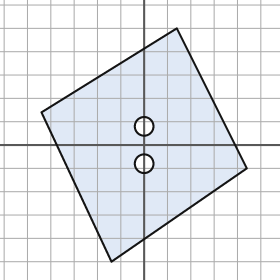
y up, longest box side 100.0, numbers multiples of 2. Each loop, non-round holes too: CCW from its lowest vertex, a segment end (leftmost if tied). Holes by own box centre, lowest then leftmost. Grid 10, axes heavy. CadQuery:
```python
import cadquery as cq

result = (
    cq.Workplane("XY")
    .moveTo(-14.0, -50.0)
    .lineTo(44.0, -10.0)
    .lineTo(14.0, 50.0)
    .lineTo(-44.0, 14.0)
    .close()
    .moveTo(0.0, -8.0)
    .circle(4.0)
    .moveTo(0.0, 8.0)
    .circle(4.0)
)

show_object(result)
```